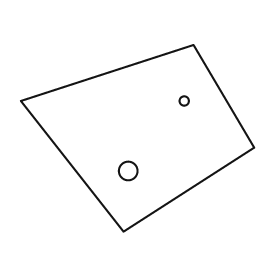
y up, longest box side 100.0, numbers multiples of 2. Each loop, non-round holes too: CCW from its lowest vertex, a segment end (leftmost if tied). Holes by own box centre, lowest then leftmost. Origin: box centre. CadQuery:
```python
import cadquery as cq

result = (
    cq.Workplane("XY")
    .moveTo(-6.0, -40.0)
    .lineTo(50.0, -4.0)
    .lineTo(24.0, 40.0)
    .lineTo(-50.0, 16.0)
    .close()
    .moveTo(-4.0, -14.0)
    .circle(4.0)
    .moveTo(20.0, 16.0)
    .circle(2.0)
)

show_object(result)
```